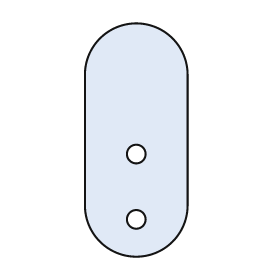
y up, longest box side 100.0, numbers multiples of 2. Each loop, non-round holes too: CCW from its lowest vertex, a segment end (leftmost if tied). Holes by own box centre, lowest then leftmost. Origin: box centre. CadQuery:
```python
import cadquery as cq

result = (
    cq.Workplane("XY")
    .moveTo(-22.0, -28.0)
    .threePointArc((0.0, -50.0), (22.0, -28.0))
    .lineTo(22.0, 28.0)
    .threePointArc((0.0, 50.0), (-22.0, 28.0))
    .close()
    .moveTo(0.0, -34.0)
    .circle(4.0)
    .moveTo(0.0, -6.0)
    .circle(4.0)
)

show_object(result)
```